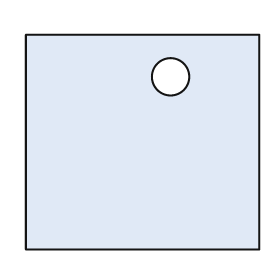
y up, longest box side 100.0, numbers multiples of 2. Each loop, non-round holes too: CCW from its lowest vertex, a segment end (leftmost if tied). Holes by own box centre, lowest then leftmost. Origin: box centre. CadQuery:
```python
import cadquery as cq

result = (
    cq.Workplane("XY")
    .moveTo(-50.0, -46.0)
    .lineTo(50.0, -46.0)
    .lineTo(50.0, 46.0)
    .lineTo(-50.0, 46.0)
    .close()
    .moveTo(12.0, 28.0)
    .circle(8.0)
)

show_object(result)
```